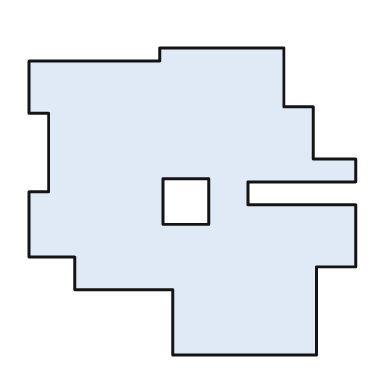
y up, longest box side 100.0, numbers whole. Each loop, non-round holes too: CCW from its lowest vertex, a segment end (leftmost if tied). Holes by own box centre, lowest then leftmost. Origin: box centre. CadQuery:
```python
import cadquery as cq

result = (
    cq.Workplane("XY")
    .moveTo(-6.0, -47.0)
    .lineTo(38.0, -47.0)
    .lineTo(38.0, -20.0)
    .lineTo(50.0, -20.0)
    .lineTo(50.0, -1.0)
    .lineTo(17.0, -1.0)
    .lineTo(17.0, 6.0)
    .lineTo(50.0, 6.0)
    .lineTo(50.0, 13.0)
    .lineTo(37.0, 13.0)
    .lineTo(37.0, 29.0)
    .lineTo(28.0, 29.0)
    .lineTo(28.0, 47.0)
    .lineTo(-10.0, 47.0)
    .lineTo(-10.0, 43.0)
    .lineTo(-50.0, 43.0)
    .lineTo(-50.0, 27.0)
    .lineTo(-44.0, 27.0)
    .lineTo(-44.0, 3.0)
    .lineTo(-50.0, 3.0)
    .lineTo(-50.0, -17.0)
    .lineTo(-36.0, -17.0)
    .lineTo(-36.0, -27.0)
    .lineTo(-6.0, -27.0)
    .close()
    .moveTo(-9.0, -7.0)
    .lineTo(5.0, -7.0)
    .lineTo(5.0, 7.0)
    .lineTo(-9.0, 7.0)
    .close()
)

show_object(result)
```